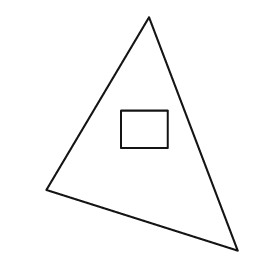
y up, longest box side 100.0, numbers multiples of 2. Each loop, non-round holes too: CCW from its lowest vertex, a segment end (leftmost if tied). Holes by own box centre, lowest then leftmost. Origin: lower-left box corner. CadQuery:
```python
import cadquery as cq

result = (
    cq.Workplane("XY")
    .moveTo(82.0, 0.0)
    .lineTo(44.0, 100.0)
    .lineTo(0.0, 26.0)
    .close()
    .moveTo(32.0, 44.0)
    .lineTo(52.0, 44.0)
    .lineTo(52.0, 60.0)
    .lineTo(32.0, 60.0)
    .close()
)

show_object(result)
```